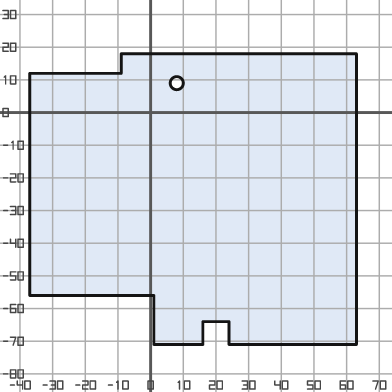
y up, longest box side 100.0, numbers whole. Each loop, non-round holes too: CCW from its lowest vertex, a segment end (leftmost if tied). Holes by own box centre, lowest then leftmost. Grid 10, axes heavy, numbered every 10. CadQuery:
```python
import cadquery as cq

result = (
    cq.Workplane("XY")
    .moveTo(1.0, -71.0)
    .lineTo(16.0, -71.0)
    .lineTo(16.0, -64.0)
    .lineTo(24.0, -64.0)
    .lineTo(24.0, -71.0)
    .lineTo(63.0, -71.0)
    .lineTo(63.0, 18.0)
    .lineTo(-9.0, 18.0)
    .lineTo(-9.0, 12.0)
    .lineTo(-37.0, 12.0)
    .lineTo(-37.0, -56.0)
    .lineTo(1.0, -56.0)
    .close()
    .moveTo(8.0, 9.0)
    .circle(2.0)
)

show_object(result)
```